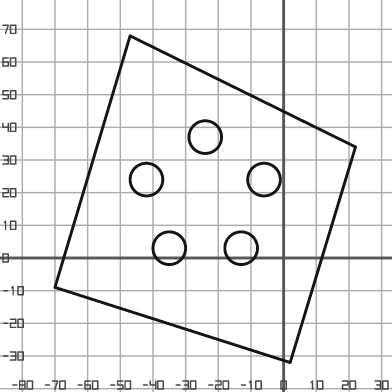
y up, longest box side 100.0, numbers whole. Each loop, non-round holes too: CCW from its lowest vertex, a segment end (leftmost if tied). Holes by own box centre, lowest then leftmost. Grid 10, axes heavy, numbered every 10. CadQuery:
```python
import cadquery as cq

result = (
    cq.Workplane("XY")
    .moveTo(2.0, -32.0)
    .lineTo(22.0, 34.0)
    .lineTo(-47.0, 68.0)
    .lineTo(-70.0, -9.0)
    .close()
    .moveTo(-35.0, 3.0)
    .circle(5.0)
    .moveTo(-13.0, 3.0)
    .circle(5.0)
    .moveTo(-42.0, 24.0)
    .circle(5.0)
    .moveTo(-6.0, 24.0)
    .circle(5.0)
    .moveTo(-24.0, 37.0)
    .circle(5.0)
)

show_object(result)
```